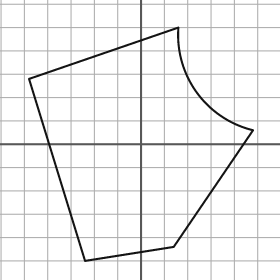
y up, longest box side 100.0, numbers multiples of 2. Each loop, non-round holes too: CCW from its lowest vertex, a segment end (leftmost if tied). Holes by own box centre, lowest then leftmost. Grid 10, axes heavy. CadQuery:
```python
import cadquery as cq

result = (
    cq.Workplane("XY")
    .moveTo(-24.0, -50.0)
    .lineTo(14.0, -44.0)
    .lineTo(48.0, 6.0)
    .threePointArc((24.0, 22.0), (16.0, 50.0))
    .lineTo(-48.0, 28.0)
    .close()
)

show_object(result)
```